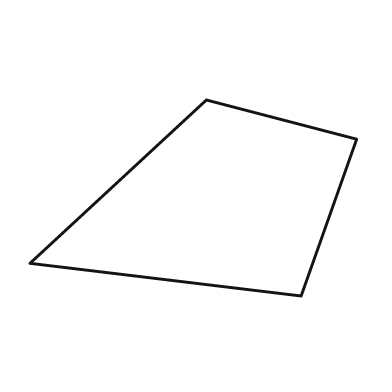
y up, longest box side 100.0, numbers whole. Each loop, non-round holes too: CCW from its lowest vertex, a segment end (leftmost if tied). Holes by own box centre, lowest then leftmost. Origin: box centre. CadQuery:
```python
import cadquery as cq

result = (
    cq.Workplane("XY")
    .moveTo(33.0, -30.0)
    .lineTo(50.0, 18.0)
    .lineTo(4.0, 30.0)
    .lineTo(-50.0, -20.0)
    .close()
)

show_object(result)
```